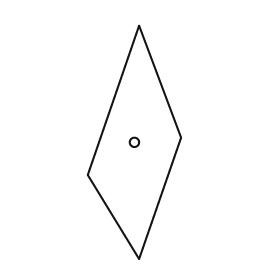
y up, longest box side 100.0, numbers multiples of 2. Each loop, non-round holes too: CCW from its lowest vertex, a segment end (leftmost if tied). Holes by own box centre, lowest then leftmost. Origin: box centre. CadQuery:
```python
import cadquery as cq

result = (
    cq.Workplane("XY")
    .moveTo(2.0, -50.0)
    .lineTo(20.0, 2.0)
    .lineTo(2.0, 50.0)
    .lineTo(-20.0, -14.0)
    .close()
    .moveTo(0.0, 0.0)
    .circle(2.0)
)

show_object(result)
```